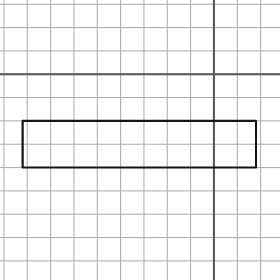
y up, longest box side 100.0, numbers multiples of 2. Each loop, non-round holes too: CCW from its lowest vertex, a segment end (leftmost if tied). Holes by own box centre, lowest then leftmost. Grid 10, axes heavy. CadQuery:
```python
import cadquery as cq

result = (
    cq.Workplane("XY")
    .moveTo(-82.0, -40.0)
    .lineTo(18.0, -40.0)
    .lineTo(18.0, -20.0)
    .lineTo(-82.0, -20.0)
    .close()
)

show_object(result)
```